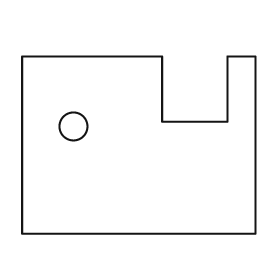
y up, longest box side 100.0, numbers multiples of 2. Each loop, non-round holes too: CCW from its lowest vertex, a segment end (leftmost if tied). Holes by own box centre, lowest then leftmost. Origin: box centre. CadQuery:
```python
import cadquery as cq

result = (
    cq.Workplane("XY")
    .moveTo(-50.0, -38.0)
    .lineTo(50.0, -38.0)
    .lineTo(50.0, 38.0)
    .lineTo(38.0, 38.0)
    .lineTo(38.0, 10.0)
    .lineTo(10.0, 10.0)
    .lineTo(10.0, 38.0)
    .lineTo(-50.0, 38.0)
    .close()
    .moveTo(-28.0, 8.0)
    .circle(6.0)
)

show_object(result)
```